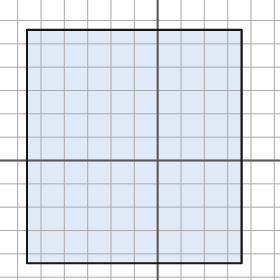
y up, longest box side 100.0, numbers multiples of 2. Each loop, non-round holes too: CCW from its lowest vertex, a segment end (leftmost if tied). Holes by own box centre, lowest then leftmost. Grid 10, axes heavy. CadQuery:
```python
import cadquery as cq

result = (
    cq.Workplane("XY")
    .moveTo(-56.0, -44.0)
    .lineTo(36.0, -44.0)
    .lineTo(36.0, 56.0)
    .lineTo(-56.0, 56.0)
    .close()
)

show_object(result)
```